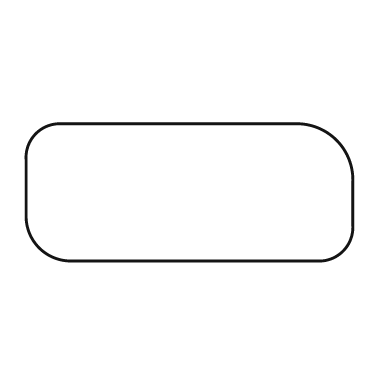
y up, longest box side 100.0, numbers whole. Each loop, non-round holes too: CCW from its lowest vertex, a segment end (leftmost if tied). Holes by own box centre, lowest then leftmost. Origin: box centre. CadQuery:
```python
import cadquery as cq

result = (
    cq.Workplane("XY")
    .moveTo(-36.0, -21.0)
    .lineTo(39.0, -21.0)
    .threePointArc((47.0, -18.0), (50.0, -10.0))
    .lineTo(50.0, 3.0)
    .threePointArc((45.0, 16.0), (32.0, 21.0))
    .lineTo(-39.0, 21.0)
    .threePointArc((-47.0, 18.0), (-50.0, 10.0))
    .lineTo(-50.0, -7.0)
    .threePointArc((-46.0, -17.0), (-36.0, -21.0))
    .close()
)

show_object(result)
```